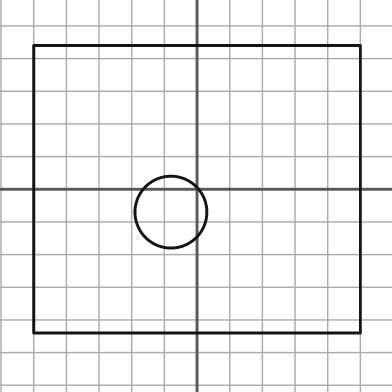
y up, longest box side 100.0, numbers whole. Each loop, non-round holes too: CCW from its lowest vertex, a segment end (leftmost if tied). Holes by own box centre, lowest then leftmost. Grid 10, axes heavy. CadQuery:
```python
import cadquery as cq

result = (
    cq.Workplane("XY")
    .moveTo(-50.0, -44.0)
    .lineTo(50.0, -44.0)
    .lineTo(50.0, 44.0)
    .lineTo(-50.0, 44.0)
    .close()
    .moveTo(-8.0, -7.0)
    .circle(11.0)
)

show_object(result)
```